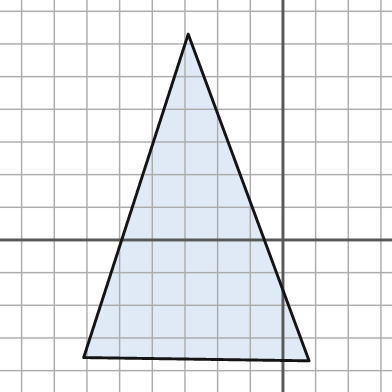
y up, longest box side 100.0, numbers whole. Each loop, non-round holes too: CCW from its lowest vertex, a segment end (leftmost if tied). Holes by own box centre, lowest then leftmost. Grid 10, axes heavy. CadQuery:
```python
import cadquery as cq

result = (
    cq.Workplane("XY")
    .moveTo(8.0, -37.0)
    .lineTo(-29.0, 63.0)
    .lineTo(-61.0, -36.0)
    .close()
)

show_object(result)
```